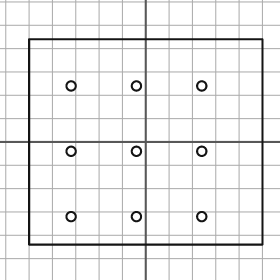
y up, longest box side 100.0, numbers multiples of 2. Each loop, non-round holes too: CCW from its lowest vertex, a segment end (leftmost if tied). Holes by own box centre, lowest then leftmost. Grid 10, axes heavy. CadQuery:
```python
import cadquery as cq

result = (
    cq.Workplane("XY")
    .moveTo(-50.0, -44.0)
    .lineTo(50.0, -44.0)
    .lineTo(50.0, 44.0)
    .lineTo(-50.0, 44.0)
    .close()
    .moveTo(-32.0, -32.0)
    .circle(2.0)
    .moveTo(-4.0, -32.0)
    .circle(2.0)
    .moveTo(24.0, -32.0)
    .circle(2.0)
    .moveTo(-32.0, -4.0)
    .circle(2.0)
    .moveTo(-4.0, -4.0)
    .circle(2.0)
    .moveTo(24.0, -4.0)
    .circle(2.0)
    .moveTo(-32.0, 24.0)
    .circle(2.0)
    .moveTo(-4.0, 24.0)
    .circle(2.0)
    .moveTo(24.0, 24.0)
    .circle(2.0)
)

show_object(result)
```